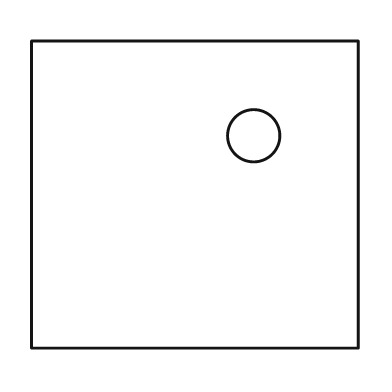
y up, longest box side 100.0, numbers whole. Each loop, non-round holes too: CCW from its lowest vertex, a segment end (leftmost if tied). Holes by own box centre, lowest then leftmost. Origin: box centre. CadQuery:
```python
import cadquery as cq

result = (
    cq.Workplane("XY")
    .moveTo(-50.0, -47.0)
    .lineTo(50.0, -47.0)
    .lineTo(50.0, 47.0)
    .lineTo(-50.0, 47.0)
    .close()
    .moveTo(18.0, 18.0)
    .circle(8.0)
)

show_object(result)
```